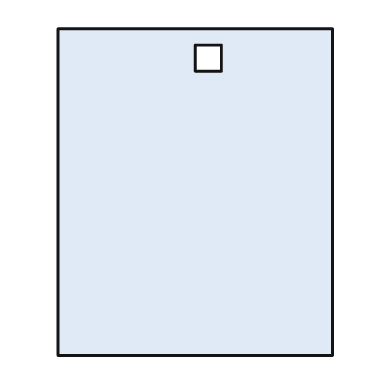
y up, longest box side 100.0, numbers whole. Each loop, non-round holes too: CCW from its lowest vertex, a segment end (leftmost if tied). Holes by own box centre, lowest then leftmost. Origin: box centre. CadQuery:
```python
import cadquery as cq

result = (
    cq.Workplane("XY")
    .moveTo(-42.0, -50.0)
    .lineTo(42.0, -50.0)
    .lineTo(42.0, 50.0)
    .lineTo(-42.0, 50.0)
    .close()
    .moveTo(0.0, 37.0)
    .lineTo(8.0, 37.0)
    .lineTo(8.0, 45.0)
    .lineTo(0.0, 45.0)
    .close()
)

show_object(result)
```